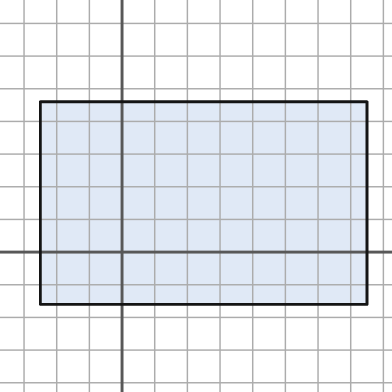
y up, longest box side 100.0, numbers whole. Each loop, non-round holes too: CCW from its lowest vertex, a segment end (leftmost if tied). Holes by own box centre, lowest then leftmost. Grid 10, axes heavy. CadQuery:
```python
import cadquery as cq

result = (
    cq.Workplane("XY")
    .moveTo(-25.0, -16.0)
    .lineTo(75.0, -16.0)
    .lineTo(75.0, 46.0)
    .lineTo(-25.0, 46.0)
    .close()
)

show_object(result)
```